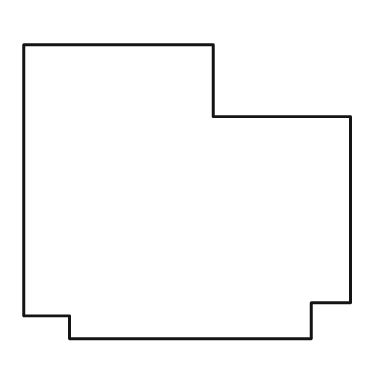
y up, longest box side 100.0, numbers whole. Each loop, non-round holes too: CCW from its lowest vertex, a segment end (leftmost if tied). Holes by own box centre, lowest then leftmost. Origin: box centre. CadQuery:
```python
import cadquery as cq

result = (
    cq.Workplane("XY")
    .moveTo(-36.0, -45.0)
    .lineTo(38.0, -45.0)
    .lineTo(38.0, -34.0)
    .lineTo(50.0, -34.0)
    .lineTo(50.0, 23.0)
    .lineTo(8.0, 23.0)
    .lineTo(8.0, 45.0)
    .lineTo(-50.0, 45.0)
    .lineTo(-50.0, -38.0)
    .lineTo(-36.0, -38.0)
    .close()
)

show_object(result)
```